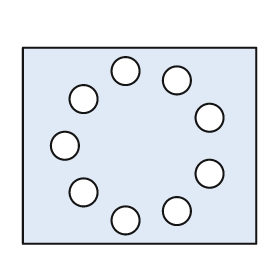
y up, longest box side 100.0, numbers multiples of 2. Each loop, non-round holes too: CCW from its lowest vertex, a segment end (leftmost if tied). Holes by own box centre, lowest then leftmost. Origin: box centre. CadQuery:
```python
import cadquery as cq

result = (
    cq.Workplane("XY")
    .moveTo(-50.0, -42.0)
    .lineTo(50.0, -42.0)
    .lineTo(50.0, 42.0)
    .lineTo(-50.0, 42.0)
    .close()
    .moveTo(-6.0, -32.0)
    .circle(6.0)
    .moveTo(16.0, -28.0)
    .circle(6.0)
    .moveTo(-24.0, -20.0)
    .circle(6.0)
    .moveTo(30.0, -12.0)
    .circle(6.0)
    .moveTo(-32.0, 0.0)
    .circle(6.0)
    .moveTo(30.0, 12.0)
    .circle(6.0)
    .moveTo(-24.0, 20.0)
    .circle(6.0)
    .moveTo(16.0, 28.0)
    .circle(6.0)
    .moveTo(-6.0, 32.0)
    .circle(6.0)
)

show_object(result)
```